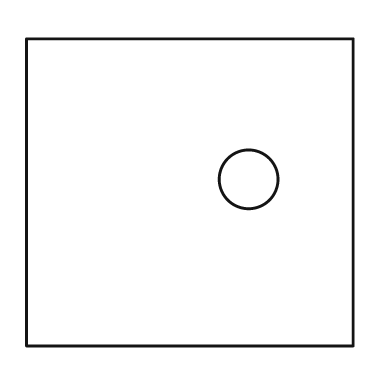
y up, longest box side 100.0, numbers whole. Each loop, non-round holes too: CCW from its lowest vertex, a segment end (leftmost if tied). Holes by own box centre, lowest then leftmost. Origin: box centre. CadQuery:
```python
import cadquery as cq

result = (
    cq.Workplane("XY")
    .moveTo(-50.0, -47.0)
    .lineTo(50.0, -47.0)
    .lineTo(50.0, 47.0)
    .lineTo(-50.0, 47.0)
    .close()
    .moveTo(18.0, 4.0)
    .circle(9.0)
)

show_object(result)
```